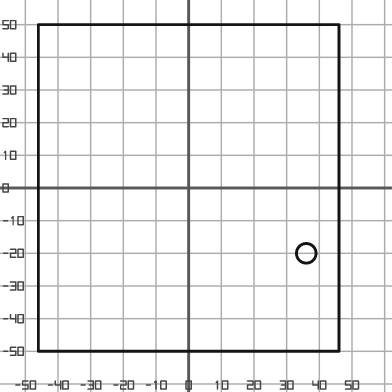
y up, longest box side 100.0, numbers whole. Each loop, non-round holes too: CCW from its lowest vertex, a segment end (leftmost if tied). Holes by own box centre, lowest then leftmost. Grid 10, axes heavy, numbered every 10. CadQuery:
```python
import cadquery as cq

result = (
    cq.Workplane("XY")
    .moveTo(-46.0, -50.0)
    .lineTo(46.0, -50.0)
    .lineTo(46.0, 50.0)
    .lineTo(-46.0, 50.0)
    .close()
    .moveTo(36.0, -20.0)
    .circle(3.0)
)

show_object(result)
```